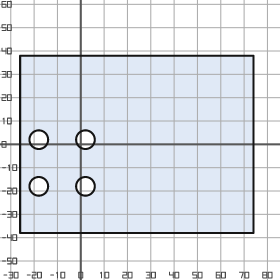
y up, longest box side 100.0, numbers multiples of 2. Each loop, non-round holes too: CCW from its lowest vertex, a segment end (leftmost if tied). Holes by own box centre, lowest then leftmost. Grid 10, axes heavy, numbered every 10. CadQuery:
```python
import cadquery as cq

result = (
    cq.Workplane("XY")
    .moveTo(-26.0, -38.0)
    .lineTo(74.0, -38.0)
    .lineTo(74.0, 38.0)
    .lineTo(-26.0, 38.0)
    .close()
    .moveTo(-18.0, -18.0)
    .circle(4.0)
    .moveTo(2.0, -18.0)
    .circle(4.0)
    .moveTo(-18.0, 2.0)
    .circle(4.0)
    .moveTo(2.0, 2.0)
    .circle(4.0)
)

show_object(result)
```